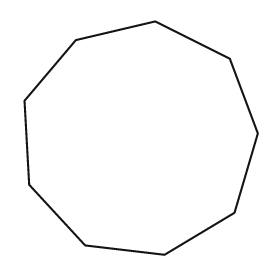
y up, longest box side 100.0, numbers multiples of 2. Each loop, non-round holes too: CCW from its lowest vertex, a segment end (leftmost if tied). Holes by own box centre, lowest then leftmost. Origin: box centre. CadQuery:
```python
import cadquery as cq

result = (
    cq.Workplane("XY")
    .moveTo(10.0, -50.0)
    .lineTo(40.0, -32.0)
    .lineTo(50.0, 2.0)
    .lineTo(38.0, 34.0)
    .lineTo(6.0, 50.0)
    .lineTo(-28.0, 42.0)
    .lineTo(-50.0, 16.0)
    .lineTo(-48.0, -20.0)
    .lineTo(-24.0, -46.0)
    .close()
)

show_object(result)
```